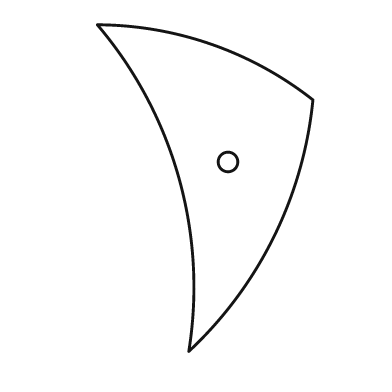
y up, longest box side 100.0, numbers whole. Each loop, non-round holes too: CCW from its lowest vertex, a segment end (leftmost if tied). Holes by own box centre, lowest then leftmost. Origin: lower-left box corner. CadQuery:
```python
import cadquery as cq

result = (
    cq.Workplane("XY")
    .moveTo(28.0, 0.0)
    .threePointArc((54.0, 35.0), (66.0, 77.0))
    .threePointArc((35.0, 94.0), (0.0, 100.0))
    .threePointArc((25.0, 53.0), (28.0, 0.0))
    .close()
    .moveTo(40.0, 58.0)
    .circle(3.0)
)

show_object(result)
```